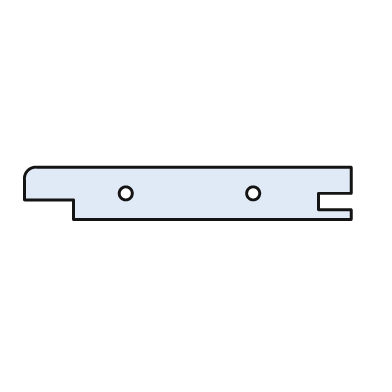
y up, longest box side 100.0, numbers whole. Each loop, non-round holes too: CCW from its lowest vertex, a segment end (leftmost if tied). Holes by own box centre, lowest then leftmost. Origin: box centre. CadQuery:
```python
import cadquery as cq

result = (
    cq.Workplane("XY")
    .moveTo(-35.0, -8.0)
    .lineTo(50.0, -8.0)
    .lineTo(50.0, -5.0)
    .lineTo(40.0, -5.0)
    .lineTo(40.0, 0.0)
    .lineTo(50.0, 0.0)
    .lineTo(50.0, 8.0)
    .lineTo(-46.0, 8.0)
    .threePointArc((-49.0, 7.0), (-50.0, 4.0))
    .lineTo(-50.0, -2.0)
    .lineTo(-35.0, -2.0)
    .close()
    .moveTo(-19.0, 0.0)
    .circle(2.0)
    .moveTo(20.0, 0.0)
    .circle(2.0)
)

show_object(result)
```